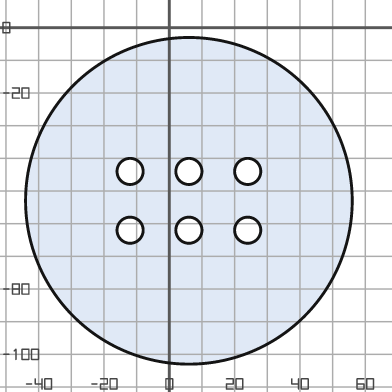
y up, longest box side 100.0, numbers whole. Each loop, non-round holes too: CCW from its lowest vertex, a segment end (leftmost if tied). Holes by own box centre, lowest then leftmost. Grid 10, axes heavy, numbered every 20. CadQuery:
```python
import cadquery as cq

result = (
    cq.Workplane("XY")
    .moveTo(6.0, -53.0)
    .circle(50.0)
    .moveTo(-12.0, -62.0)
    .circle(4.0)
    .moveTo(6.0, -62.0)
    .circle(4.0)
    .moveTo(24.0, -62.0)
    .circle(4.0)
    .moveTo(-12.0, -44.0)
    .circle(4.0)
    .moveTo(6.0, -44.0)
    .circle(4.0)
    .moveTo(24.0, -44.0)
    .circle(4.0)
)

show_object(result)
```